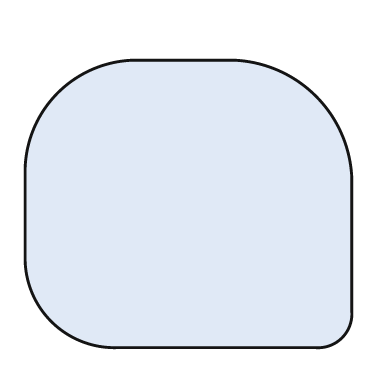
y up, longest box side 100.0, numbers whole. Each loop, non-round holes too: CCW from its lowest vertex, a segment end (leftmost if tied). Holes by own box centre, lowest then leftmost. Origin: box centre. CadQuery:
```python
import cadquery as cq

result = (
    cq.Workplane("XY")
    .moveTo(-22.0, -44.0)
    .lineTo(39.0, -44.0)
    .threePointArc((47.0, -41.0), (50.0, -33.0))
    .lineTo(50.0, 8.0)
    .threePointArc((39.0, 33.0), (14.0, 44.0))
    .lineTo(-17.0, 44.0)
    .threePointArc((-40.0, 34.0), (-50.0, 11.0))
    .lineTo(-50.0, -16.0)
    .threePointArc((-42.0, -36.0), (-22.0, -44.0))
    .close()
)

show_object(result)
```